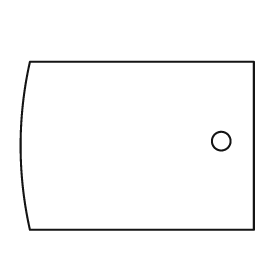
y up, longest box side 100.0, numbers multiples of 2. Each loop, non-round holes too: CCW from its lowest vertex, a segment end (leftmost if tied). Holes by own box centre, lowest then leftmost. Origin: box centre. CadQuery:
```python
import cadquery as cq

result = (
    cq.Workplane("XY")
    .moveTo(-46.0, -36.0)
    .lineTo(50.0, -36.0)
    .lineTo(50.0, 36.0)
    .lineTo(-46.0, 36.0)
    .threePointArc((-50.0, 0.0), (-46.0, -36.0))
    .close()
    .moveTo(36.0, 2.0)
    .circle(4.0)
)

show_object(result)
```